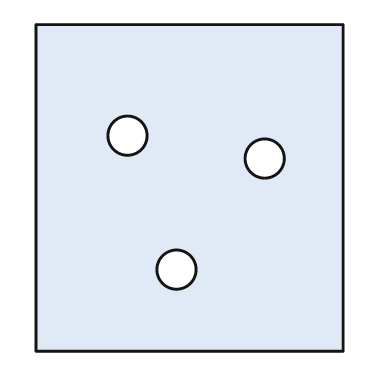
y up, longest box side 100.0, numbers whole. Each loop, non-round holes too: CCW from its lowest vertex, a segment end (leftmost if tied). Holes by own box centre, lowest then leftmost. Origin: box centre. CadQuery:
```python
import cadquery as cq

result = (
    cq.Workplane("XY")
    .moveTo(-47.0, -50.0)
    .lineTo(47.0, -50.0)
    .lineTo(47.0, 50.0)
    .lineTo(-47.0, 50.0)
    .close()
    .moveTo(-4.0, -25.0)
    .circle(6.0)
    .moveTo(23.0, 9.0)
    .circle(6.0)
    .moveTo(-19.0, 16.0)
    .circle(6.0)
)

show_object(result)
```